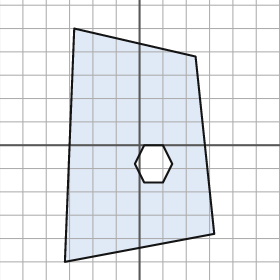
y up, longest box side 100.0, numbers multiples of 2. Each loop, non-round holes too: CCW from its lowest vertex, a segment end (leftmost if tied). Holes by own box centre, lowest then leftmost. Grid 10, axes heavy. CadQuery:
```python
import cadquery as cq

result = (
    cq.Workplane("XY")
    .moveTo(-32.0, -50.0)
    .lineTo(32.0, -38.0)
    .lineTo(24.0, 38.0)
    .lineTo(-28.0, 50.0)
    .close()
    .moveTo(2.0, -16.0)
    .lineTo(10.0, -16.0)
    .lineTo(14.0, -8.0)
    .lineTo(10.0, 0.0)
    .lineTo(2.0, 0.0)
    .lineTo(-2.0, -8.0)
    .close()
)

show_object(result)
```